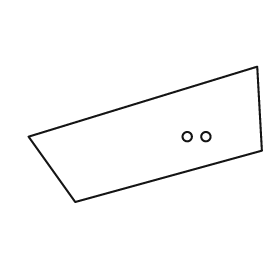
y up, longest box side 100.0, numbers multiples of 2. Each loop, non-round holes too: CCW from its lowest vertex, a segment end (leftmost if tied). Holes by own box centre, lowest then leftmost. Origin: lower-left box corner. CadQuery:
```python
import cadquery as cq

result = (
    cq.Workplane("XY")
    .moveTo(20.0, 0.0)
    .lineTo(100.0, 22.0)
    .lineTo(98.0, 58.0)
    .lineTo(0.0, 28.0)
    .close()
    .moveTo(68.0, 28.0)
    .circle(2.0)
    .moveTo(76.0, 28.0)
    .circle(2.0)
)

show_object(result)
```